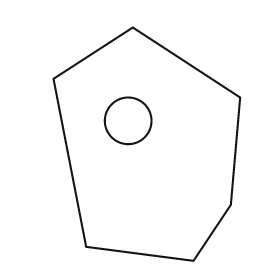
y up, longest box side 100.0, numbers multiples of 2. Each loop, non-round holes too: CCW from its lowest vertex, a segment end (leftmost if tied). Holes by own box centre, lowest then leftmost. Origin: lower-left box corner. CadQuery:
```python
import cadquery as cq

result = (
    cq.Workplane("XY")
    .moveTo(60.0, 0.0)
    .lineTo(76.0, 24.0)
    .lineTo(80.0, 70.0)
    .lineTo(34.0, 100.0)
    .lineTo(0.0, 78.0)
    .lineTo(14.0, 6.0)
    .close()
    .moveTo(32.0, 60.0)
    .circle(10.0)
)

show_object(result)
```